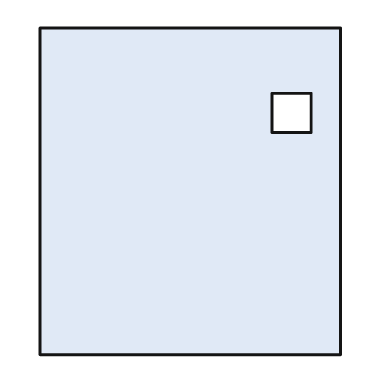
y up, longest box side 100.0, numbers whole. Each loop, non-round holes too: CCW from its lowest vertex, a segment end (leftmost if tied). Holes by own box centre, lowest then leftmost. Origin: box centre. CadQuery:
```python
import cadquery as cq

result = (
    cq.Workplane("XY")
    .moveTo(-46.0, -50.0)
    .lineTo(46.0, -50.0)
    .lineTo(46.0, 50.0)
    .lineTo(-46.0, 50.0)
    .close()
    .moveTo(25.0, 18.0)
    .lineTo(37.0, 18.0)
    .lineTo(37.0, 30.0)
    .lineTo(25.0, 30.0)
    .close()
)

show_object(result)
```